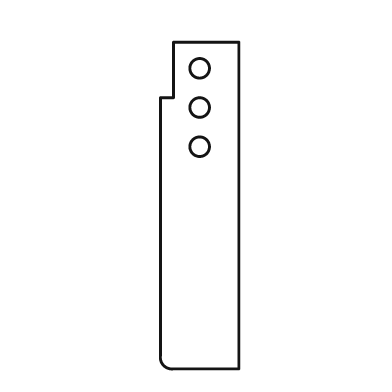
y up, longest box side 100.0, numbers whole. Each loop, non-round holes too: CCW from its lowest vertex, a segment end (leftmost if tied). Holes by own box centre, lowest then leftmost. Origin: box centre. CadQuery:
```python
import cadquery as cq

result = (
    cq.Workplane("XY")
    .moveTo(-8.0, -50.0)
    .lineTo(12.0, -50.0)
    .lineTo(12.0, 50.0)
    .lineTo(-8.0, 50.0)
    .lineTo(-8.0, 33.0)
    .lineTo(-12.0, 33.0)
    .lineTo(-12.0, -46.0)
    .threePointArc((-11.0, -49.0), (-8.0, -50.0))
    .close()
    .moveTo(0.0, 18.0)
    .circle(3.0)
    .moveTo(0.0, 30.0)
    .circle(3.0)
    .moveTo(0.0, 42.0)
    .circle(3.0)
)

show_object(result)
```